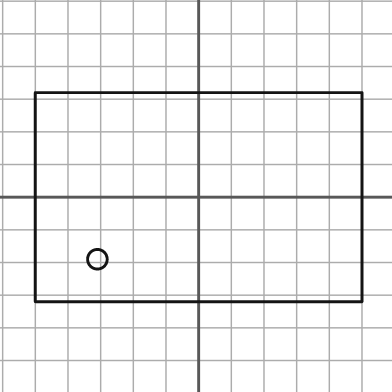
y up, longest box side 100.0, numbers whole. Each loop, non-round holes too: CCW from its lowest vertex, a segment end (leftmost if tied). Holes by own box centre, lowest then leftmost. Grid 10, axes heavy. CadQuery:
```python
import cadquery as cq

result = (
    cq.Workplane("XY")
    .moveTo(-50.0, -32.0)
    .lineTo(50.0, -32.0)
    .lineTo(50.0, 32.0)
    .lineTo(-50.0, 32.0)
    .close()
    .moveTo(-31.0, -19.0)
    .circle(3.0)
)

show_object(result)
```